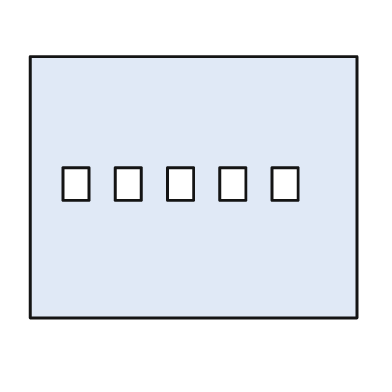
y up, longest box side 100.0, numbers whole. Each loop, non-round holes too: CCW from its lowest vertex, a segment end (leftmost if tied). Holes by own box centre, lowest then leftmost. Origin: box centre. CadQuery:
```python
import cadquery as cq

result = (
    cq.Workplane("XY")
    .moveTo(-50.0, -40.0)
    .lineTo(50.0, -40.0)
    .lineTo(50.0, 40.0)
    .lineTo(-50.0, 40.0)
    .close()
    .moveTo(-40.0, -4.0)
    .lineTo(-32.0, -4.0)
    .lineTo(-32.0, 6.0)
    .lineTo(-40.0, 6.0)
    .close()
    .moveTo(-24.0, -4.0)
    .lineTo(-16.0, -4.0)
    .lineTo(-16.0, 6.0)
    .lineTo(-24.0, 6.0)
    .close()
    .moveTo(-8.0, -4.0)
    .lineTo(0.0, -4.0)
    .lineTo(0.0, 6.0)
    .lineTo(-8.0, 6.0)
    .close()
    .moveTo(8.0, -4.0)
    .lineTo(16.0, -4.0)
    .lineTo(16.0, 6.0)
    .lineTo(8.0, 6.0)
    .close()
    .moveTo(24.0, -4.0)
    .lineTo(32.0, -4.0)
    .lineTo(32.0, 6.0)
    .lineTo(24.0, 6.0)
    .close()
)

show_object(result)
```